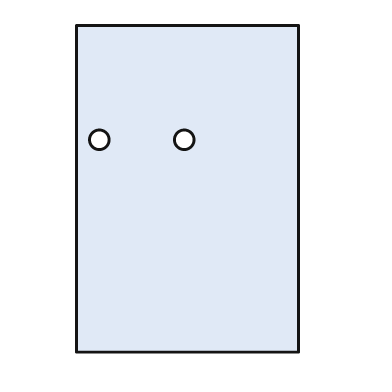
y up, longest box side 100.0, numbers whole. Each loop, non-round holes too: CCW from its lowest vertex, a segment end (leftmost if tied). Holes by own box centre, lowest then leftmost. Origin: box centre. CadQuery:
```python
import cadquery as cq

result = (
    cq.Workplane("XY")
    .moveTo(-34.0, -50.0)
    .lineTo(34.0, -50.0)
    .lineTo(34.0, 50.0)
    .lineTo(-34.0, 50.0)
    .close()
    .moveTo(-27.0, 15.0)
    .circle(3.0)
    .moveTo(-1.0, 15.0)
    .circle(3.0)
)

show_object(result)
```